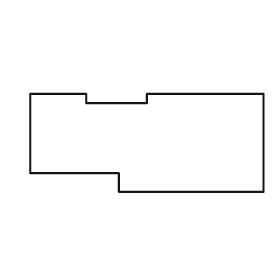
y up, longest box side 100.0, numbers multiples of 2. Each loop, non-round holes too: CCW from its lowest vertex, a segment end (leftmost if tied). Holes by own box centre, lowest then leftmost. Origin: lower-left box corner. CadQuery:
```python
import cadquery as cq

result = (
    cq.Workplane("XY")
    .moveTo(38.0, 0.0)
    .lineTo(100.0, 0.0)
    .lineTo(100.0, 42.0)
    .lineTo(50.0, 42.0)
    .lineTo(50.0, 38.0)
    .lineTo(24.0, 38.0)
    .lineTo(24.0, 42.0)
    .lineTo(0.0, 42.0)
    .lineTo(0.0, 8.0)
    .lineTo(38.0, 8.0)
    .close()
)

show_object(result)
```